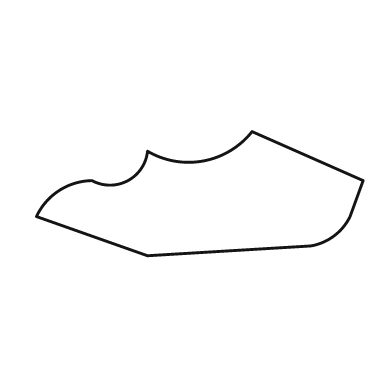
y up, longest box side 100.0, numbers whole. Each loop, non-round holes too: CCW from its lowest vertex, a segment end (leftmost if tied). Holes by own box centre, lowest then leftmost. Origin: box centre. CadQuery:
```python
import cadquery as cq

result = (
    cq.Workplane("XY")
    .moveTo(-16.0, -19.0)
    .lineTo(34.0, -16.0)
    .threePointArc((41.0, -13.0), (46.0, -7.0))
    .lineTo(50.0, 4.0)
    .lineTo(16.0, 19.0)
    .threePointArc((1.0, 10.0), (-16.0, 13.0))
    .threePointArc((-22.0, 4.0), (-33.0, 4.0))
    .threePointArc((-43.0, 1.0), (-50.0, -7.0))
    .close()
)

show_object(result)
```